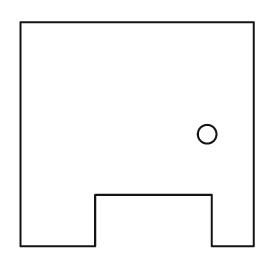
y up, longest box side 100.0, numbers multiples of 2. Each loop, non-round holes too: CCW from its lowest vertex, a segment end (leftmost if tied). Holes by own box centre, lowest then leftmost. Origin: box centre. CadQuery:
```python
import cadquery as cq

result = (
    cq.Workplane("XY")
    .moveTo(-50.0, -48.0)
    .lineTo(-18.0, -48.0)
    .lineTo(-18.0, -26.0)
    .lineTo(32.0, -26.0)
    .lineTo(32.0, -48.0)
    .lineTo(50.0, -48.0)
    .lineTo(50.0, 48.0)
    .lineTo(-50.0, 48.0)
    .close()
    .moveTo(30.0, 0.0)
    .circle(4.0)
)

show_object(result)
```